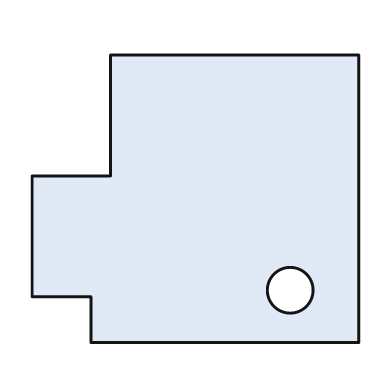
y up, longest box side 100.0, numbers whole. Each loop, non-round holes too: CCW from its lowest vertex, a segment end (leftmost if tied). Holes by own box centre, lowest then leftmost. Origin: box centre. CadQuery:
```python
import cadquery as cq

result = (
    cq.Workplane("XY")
    .moveTo(-32.0, -44.0)
    .lineTo(50.0, -44.0)
    .lineTo(50.0, 44.0)
    .lineTo(-26.0, 44.0)
    .lineTo(-26.0, 7.0)
    .lineTo(-50.0, 7.0)
    .lineTo(-50.0, -30.0)
    .lineTo(-32.0, -30.0)
    .close()
    .moveTo(29.0, -28.0)
    .circle(7.0)
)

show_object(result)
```